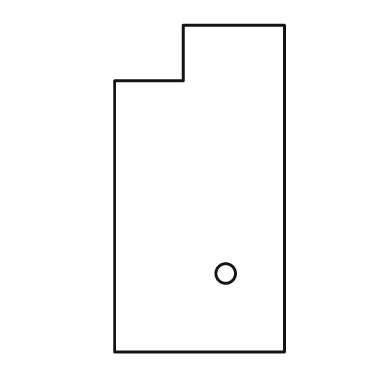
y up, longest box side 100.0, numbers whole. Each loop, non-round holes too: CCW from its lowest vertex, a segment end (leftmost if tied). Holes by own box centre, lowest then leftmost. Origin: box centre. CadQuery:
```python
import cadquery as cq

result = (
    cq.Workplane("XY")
    .moveTo(-26.0, -50.0)
    .lineTo(26.0, -50.0)
    .lineTo(26.0, 50.0)
    .lineTo(-5.0, 50.0)
    .lineTo(-5.0, 33.0)
    .lineTo(-26.0, 33.0)
    .close()
    .moveTo(8.0, -26.0)
    .circle(3.0)
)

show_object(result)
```